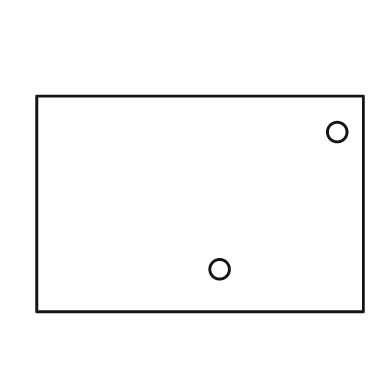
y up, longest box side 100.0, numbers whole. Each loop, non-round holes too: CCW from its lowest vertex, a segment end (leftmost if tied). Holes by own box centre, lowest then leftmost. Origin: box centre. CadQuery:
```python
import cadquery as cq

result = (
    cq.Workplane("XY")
    .moveTo(-50.0, -33.0)
    .lineTo(50.0, -33.0)
    .lineTo(50.0, 33.0)
    .lineTo(-50.0, 33.0)
    .close()
    .moveTo(6.0, -20.0)
    .circle(3.0)
    .moveTo(42.0, 22.0)
    .circle(3.0)
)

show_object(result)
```